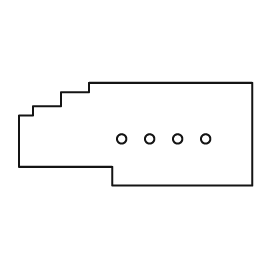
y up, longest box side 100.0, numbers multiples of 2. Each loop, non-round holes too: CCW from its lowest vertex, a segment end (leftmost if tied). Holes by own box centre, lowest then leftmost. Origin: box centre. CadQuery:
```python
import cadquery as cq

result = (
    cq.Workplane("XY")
    .moveTo(-10.0, -22.0)
    .lineTo(50.0, -22.0)
    .lineTo(50.0, 22.0)
    .lineTo(-20.0, 22.0)
    .lineTo(-20.0, 18.0)
    .lineTo(-32.0, 18.0)
    .lineTo(-32.0, 12.0)
    .lineTo(-44.0, 12.0)
    .lineTo(-44.0, 8.0)
    .lineTo(-50.0, 8.0)
    .lineTo(-50.0, -14.0)
    .lineTo(-10.0, -14.0)
    .close()
    .moveTo(-6.0, -2.0)
    .circle(2.0)
    .moveTo(6.0, -2.0)
    .circle(2.0)
    .moveTo(18.0, -2.0)
    .circle(2.0)
    .moveTo(30.0, -2.0)
    .circle(2.0)
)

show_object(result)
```